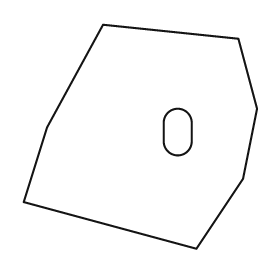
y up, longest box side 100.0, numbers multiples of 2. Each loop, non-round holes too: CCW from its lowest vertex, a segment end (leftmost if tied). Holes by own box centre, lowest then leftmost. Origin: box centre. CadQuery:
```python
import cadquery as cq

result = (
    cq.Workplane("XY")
    .moveTo(24.0, -48.0)
    .lineTo(44.0, -18.0)
    .lineTo(50.0, 12.0)
    .lineTo(42.0, 42.0)
    .lineTo(-16.0, 48.0)
    .lineTo(-40.0, 4.0)
    .lineTo(-50.0, -28.0)
    .close()
    .moveTo(10.0, -2.0)
    .threePointArc((16.0, -8.0), (22.0, -2.0))
    .lineTo(22.0, 6.0)
    .threePointArc((16.0, 12.0), (10.0, 6.0))
    .close()
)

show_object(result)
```